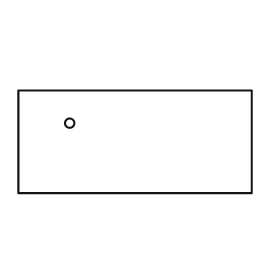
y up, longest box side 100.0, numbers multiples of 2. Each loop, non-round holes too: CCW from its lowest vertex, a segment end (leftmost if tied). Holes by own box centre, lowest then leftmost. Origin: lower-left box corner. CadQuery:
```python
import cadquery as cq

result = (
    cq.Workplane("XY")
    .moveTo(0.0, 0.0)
    .lineTo(100.0, 0.0)
    .lineTo(100.0, 44.0)
    .lineTo(0.0, 44.0)
    .close()
    .moveTo(22.0, 30.0)
    .circle(2.0)
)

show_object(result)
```